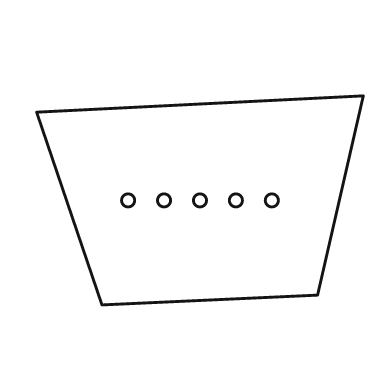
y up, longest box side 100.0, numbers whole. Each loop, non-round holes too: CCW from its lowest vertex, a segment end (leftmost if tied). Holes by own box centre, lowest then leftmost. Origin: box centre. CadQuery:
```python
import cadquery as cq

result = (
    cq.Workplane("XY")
    .moveTo(-30.0, -32.0)
    .lineTo(36.0, -29.0)
    .lineTo(50.0, 32.0)
    .lineTo(-50.0, 27.0)
    .close()
    .moveTo(-22.0, 0.0)
    .circle(2.0)
    .moveTo(-11.0, 0.0)
    .circle(2.0)
    .moveTo(0.0, 0.0)
    .circle(2.0)
    .moveTo(11.0, 0.0)
    .circle(2.0)
    .moveTo(22.0, 0.0)
    .circle(2.0)
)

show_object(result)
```